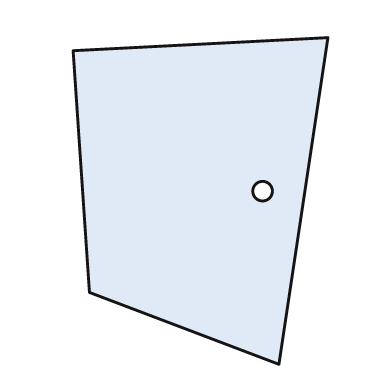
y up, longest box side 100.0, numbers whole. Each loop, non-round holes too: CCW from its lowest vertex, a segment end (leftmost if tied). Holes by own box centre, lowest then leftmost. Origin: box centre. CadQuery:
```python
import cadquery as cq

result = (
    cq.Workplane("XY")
    .moveTo(24.0, -50.0)
    .lineTo(39.0, 50.0)
    .lineTo(-39.0, 46.0)
    .lineTo(-34.0, -28.0)
    .close()
    .moveTo(19.0, 3.0)
    .circle(3.0)
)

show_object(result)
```